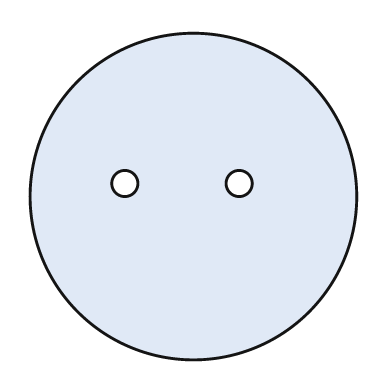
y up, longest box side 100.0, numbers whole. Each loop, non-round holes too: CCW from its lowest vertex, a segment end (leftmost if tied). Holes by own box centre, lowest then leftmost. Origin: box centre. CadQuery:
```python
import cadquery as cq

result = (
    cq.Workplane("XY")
    .moveTo(0.0, 0.0)
    .circle(50.0)
    .moveTo(-21.0, 4.0)
    .circle(4.0)
    .moveTo(14.0, 4.0)
    .circle(4.0)
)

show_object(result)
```